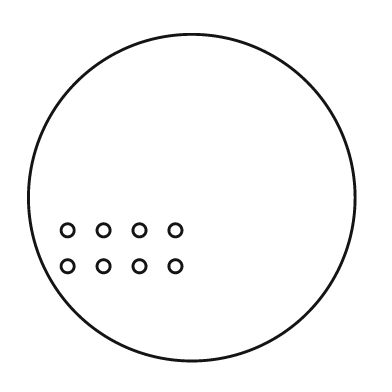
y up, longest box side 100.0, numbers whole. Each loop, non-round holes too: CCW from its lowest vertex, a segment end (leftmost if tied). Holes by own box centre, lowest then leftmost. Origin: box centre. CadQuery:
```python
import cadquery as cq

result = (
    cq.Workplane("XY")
    .moveTo(0.0, 0.0)
    .circle(50.0)
    .moveTo(-38.0, -21.0)
    .circle(2.0)
    .moveTo(-27.0, -21.0)
    .circle(2.0)
    .moveTo(-16.0, -21.0)
    .circle(2.0)
    .moveTo(-5.0, -21.0)
    .circle(2.0)
    .moveTo(-38.0, -10.0)
    .circle(2.0)
    .moveTo(-27.0, -10.0)
    .circle(2.0)
    .moveTo(-16.0, -10.0)
    .circle(2.0)
    .moveTo(-5.0, -10.0)
    .circle(2.0)
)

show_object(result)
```